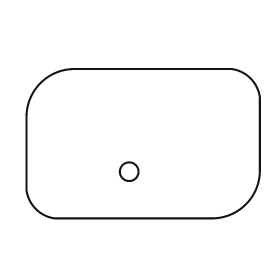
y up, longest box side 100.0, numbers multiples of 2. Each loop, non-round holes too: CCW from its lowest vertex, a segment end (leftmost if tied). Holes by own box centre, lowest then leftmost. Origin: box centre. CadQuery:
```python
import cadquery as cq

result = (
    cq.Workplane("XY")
    .moveTo(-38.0, -32.0)
    .lineTo(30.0, -32.0)
    .threePointArc((44.0, -26.0), (50.0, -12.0))
    .lineTo(50.0, 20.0)
    .threePointArc((46.0, 28.0), (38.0, 32.0))
    .lineTo(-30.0, 32.0)
    .threePointArc((-44.0, 26.0), (-50.0, 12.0))
    .lineTo(-50.0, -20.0)
    .threePointArc((-46.0, -28.0), (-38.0, -32.0))
    .close()
    .moveTo(-6.0, -12.0)
    .circle(4.0)
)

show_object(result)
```